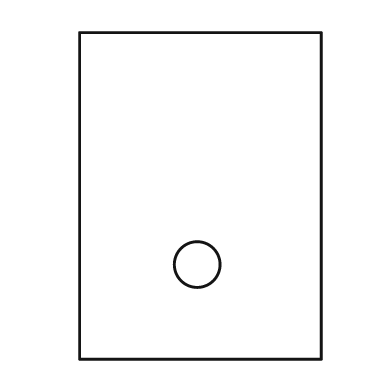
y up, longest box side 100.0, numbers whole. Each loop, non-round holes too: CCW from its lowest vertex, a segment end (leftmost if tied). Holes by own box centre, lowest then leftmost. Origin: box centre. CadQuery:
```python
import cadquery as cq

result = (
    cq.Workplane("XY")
    .moveTo(-37.0, -50.0)
    .lineTo(37.0, -50.0)
    .lineTo(37.0, 50.0)
    .lineTo(-37.0, 50.0)
    .close()
    .moveTo(-1.0, -21.0)
    .circle(7.0)
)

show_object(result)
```